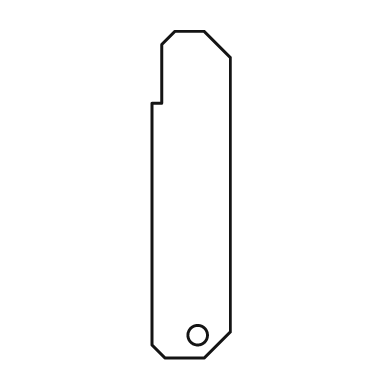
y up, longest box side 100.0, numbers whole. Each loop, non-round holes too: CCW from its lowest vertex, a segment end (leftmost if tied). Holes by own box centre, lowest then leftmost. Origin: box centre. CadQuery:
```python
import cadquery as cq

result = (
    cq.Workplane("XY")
    .moveTo(-8.0, -50.0)
    .lineTo(4.0, -50.0)
    .lineTo(12.0, -42.0)
    .lineTo(12.0, 42.0)
    .lineTo(4.0, 50.0)
    .lineTo(-5.0, 50.0)
    .lineTo(-9.0, 46.0)
    .lineTo(-9.0, 28.0)
    .lineTo(-12.0, 28.0)
    .lineTo(-12.0, -46.0)
    .close()
    .moveTo(2.0, -43.0)
    .circle(3.0)
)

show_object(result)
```